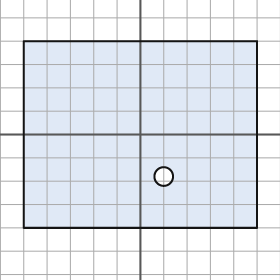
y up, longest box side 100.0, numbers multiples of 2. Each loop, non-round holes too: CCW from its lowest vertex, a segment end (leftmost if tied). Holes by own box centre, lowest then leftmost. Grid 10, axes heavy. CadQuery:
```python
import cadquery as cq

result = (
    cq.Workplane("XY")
    .moveTo(-50.0, -40.0)
    .lineTo(50.0, -40.0)
    .lineTo(50.0, 40.0)
    .lineTo(-50.0, 40.0)
    .close()
    .moveTo(10.0, -18.0)
    .circle(4.0)
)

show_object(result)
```